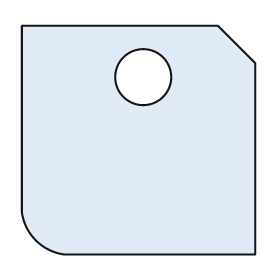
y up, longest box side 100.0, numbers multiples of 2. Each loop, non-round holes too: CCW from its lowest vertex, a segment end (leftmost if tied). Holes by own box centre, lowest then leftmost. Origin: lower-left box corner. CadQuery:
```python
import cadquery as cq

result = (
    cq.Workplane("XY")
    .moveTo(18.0, 0.0)
    .lineTo(100.0, 0.0)
    .lineTo(100.0, 82.0)
    .lineTo(84.0, 98.0)
    .lineTo(0.0, 98.0)
    .lineTo(0.0, 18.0)
    .threePointArc((6.0, 6.0), (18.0, 0.0))
    .close()
    .moveTo(52.0, 76.0)
    .circle(12.0)
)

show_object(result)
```